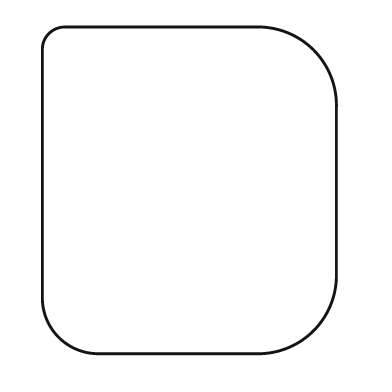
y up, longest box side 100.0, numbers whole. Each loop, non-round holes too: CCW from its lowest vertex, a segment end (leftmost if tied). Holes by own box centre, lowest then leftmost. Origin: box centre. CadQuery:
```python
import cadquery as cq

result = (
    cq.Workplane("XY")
    .moveTo(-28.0, -50.0)
    .lineTo(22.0, -50.0)
    .threePointArc((38.0, -43.0), (45.0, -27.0))
    .lineTo(45.0, 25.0)
    .threePointArc((38.0, 43.0), (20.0, 50.0))
    .lineTo(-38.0, 50.0)
    .threePointArc((-43.0, 48.0), (-45.0, 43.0))
    .lineTo(-45.0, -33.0)
    .threePointArc((-40.0, -45.0), (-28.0, -50.0))
    .close()
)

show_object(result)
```